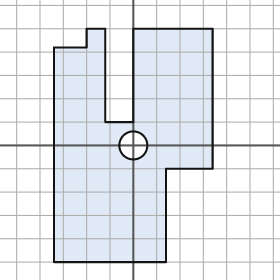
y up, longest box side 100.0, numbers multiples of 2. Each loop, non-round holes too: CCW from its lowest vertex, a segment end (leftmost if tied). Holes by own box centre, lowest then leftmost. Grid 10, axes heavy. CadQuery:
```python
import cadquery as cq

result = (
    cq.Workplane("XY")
    .moveTo(-34.0, -50.0)
    .lineTo(14.0, -50.0)
    .lineTo(14.0, -10.0)
    .lineTo(34.0, -10.0)
    .lineTo(34.0, 50.0)
    .lineTo(0.0, 50.0)
    .lineTo(0.0, 10.0)
    .lineTo(-12.0, 10.0)
    .lineTo(-12.0, 50.0)
    .lineTo(-20.0, 50.0)
    .lineTo(-20.0, 42.0)
    .lineTo(-34.0, 42.0)
    .close()
    .moveTo(0.0, 0.0)
    .circle(6.0)
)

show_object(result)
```